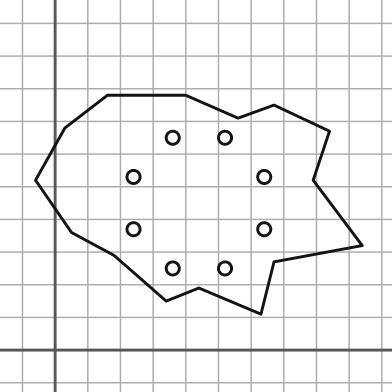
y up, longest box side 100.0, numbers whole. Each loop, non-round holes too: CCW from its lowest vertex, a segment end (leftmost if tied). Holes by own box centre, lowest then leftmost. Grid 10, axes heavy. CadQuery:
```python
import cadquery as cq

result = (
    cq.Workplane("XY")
    .moveTo(63.0, 11.0)
    .lineTo(67.0, 27.0)
    .lineTo(94.0, 32.0)
    .lineTo(79.0, 52.0)
    .lineTo(84.0, 67.0)
    .lineTo(67.0, 75.0)
    .lineTo(56.0, 71.0)
    .lineTo(40.0, 78.0)
    .lineTo(16.0, 78.0)
    .lineTo(3.0, 68.0)
    .lineTo(-6.0, 52.0)
    .lineTo(5.0, 36.0)
    .lineTo(18.0, 29.0)
    .lineTo(34.0, 15.0)
    .lineTo(44.0, 19.0)
    .close()
    .moveTo(36.0, 25.0)
    .circle(2.0)
    .moveTo(52.0, 25.0)
    .circle(2.0)
    .moveTo(24.0, 37.0)
    .circle(2.0)
    .moveTo(64.0, 37.0)
    .circle(2.0)
    .moveTo(24.0, 53.0)
    .circle(2.0)
    .moveTo(64.0, 53.0)
    .circle(2.0)
    .moveTo(36.0, 65.0)
    .circle(2.0)
    .moveTo(52.0, 65.0)
    .circle(2.0)
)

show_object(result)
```